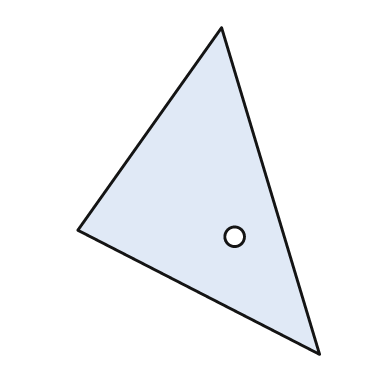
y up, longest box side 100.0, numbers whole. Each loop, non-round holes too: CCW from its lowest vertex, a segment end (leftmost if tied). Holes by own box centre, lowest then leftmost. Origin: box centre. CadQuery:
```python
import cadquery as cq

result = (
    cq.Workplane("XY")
    .moveTo(37.0, -50.0)
    .lineTo(7.0, 50.0)
    .lineTo(-37.0, -12.0)
    .close()
    .moveTo(11.0, -14.0)
    .circle(3.0)
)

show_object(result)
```